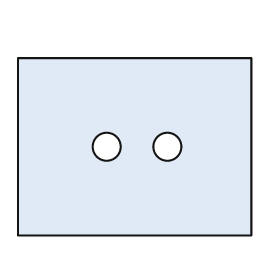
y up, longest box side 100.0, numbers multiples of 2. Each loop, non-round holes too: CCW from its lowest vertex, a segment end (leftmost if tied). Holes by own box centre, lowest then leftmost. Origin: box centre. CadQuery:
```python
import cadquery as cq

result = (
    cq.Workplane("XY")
    .moveTo(-50.0, -38.0)
    .lineTo(50.0, -38.0)
    .lineTo(50.0, 38.0)
    .lineTo(-50.0, 38.0)
    .close()
    .moveTo(-12.0, 0.0)
    .circle(6.0)
    .moveTo(14.0, 0.0)
    .circle(6.0)
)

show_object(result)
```